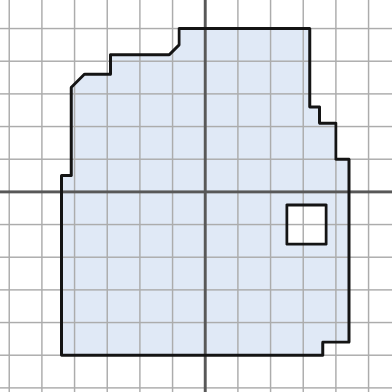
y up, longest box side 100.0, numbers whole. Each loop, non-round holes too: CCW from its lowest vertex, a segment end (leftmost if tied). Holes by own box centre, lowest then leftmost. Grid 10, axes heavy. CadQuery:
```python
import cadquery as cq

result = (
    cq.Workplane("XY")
    .moveTo(-44.0, -50.0)
    .lineTo(36.0, -50.0)
    .lineTo(36.0, -46.0)
    .lineTo(44.0, -46.0)
    .lineTo(44.0, 10.0)
    .lineTo(40.0, 10.0)
    .lineTo(40.0, 21.0)
    .lineTo(35.0, 21.0)
    .lineTo(35.0, 26.0)
    .lineTo(32.0, 26.0)
    .lineTo(32.0, 50.0)
    .lineTo(-8.0, 50.0)
    .lineTo(-8.0, 45.0)
    .lineTo(-11.0, 42.0)
    .lineTo(-29.0, 42.0)
    .lineTo(-29.0, 36.0)
    .lineTo(-37.0, 36.0)
    .lineTo(-41.0, 32.0)
    .lineTo(-41.0, 5.0)
    .lineTo(-44.0, 5.0)
    .close()
    .moveTo(25.0, -16.0)
    .lineTo(37.0, -16.0)
    .lineTo(37.0, -4.0)
    .lineTo(25.0, -4.0)
    .close()
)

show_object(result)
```